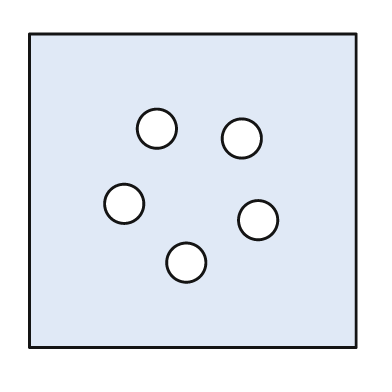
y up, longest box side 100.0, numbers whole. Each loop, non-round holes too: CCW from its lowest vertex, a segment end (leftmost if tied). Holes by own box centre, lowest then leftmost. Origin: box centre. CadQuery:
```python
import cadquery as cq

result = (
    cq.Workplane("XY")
    .moveTo(-50.0, -48.0)
    .lineTo(50.0, -48.0)
    .lineTo(50.0, 48.0)
    .lineTo(-50.0, 48.0)
    .close()
    .moveTo(-2.0, -22.0)
    .circle(6.0)
    .moveTo(20.0, -9.0)
    .circle(6.0)
    .moveTo(-21.0, -4.0)
    .circle(6.0)
    .moveTo(15.0, 16.0)
    .circle(6.0)
    .moveTo(-11.0, 19.0)
    .circle(6.0)
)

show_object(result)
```